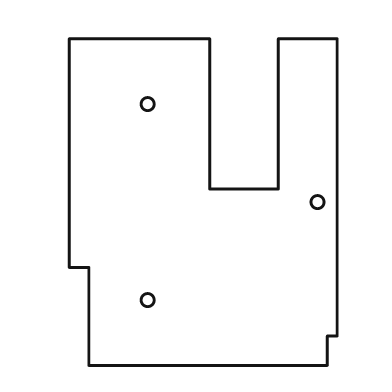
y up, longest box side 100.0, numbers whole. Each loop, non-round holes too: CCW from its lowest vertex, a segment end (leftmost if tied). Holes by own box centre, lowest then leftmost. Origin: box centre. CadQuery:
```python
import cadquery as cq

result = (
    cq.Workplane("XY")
    .moveTo(-35.0, -50.0)
    .lineTo(38.0, -50.0)
    .lineTo(38.0, -41.0)
    .lineTo(41.0, -41.0)
    .lineTo(41.0, 50.0)
    .lineTo(23.0, 50.0)
    .lineTo(23.0, 4.0)
    .lineTo(2.0, 4.0)
    .lineTo(2.0, 50.0)
    .lineTo(-41.0, 50.0)
    .lineTo(-41.0, -20.0)
    .lineTo(-35.0, -20.0)
    .close()
    .moveTo(-17.0, -30.0)
    .circle(2.0)
    .moveTo(35.0, 0.0)
    .circle(2.0)
    .moveTo(-17.0, 30.0)
    .circle(2.0)
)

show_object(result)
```